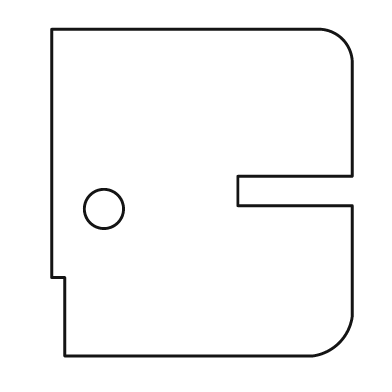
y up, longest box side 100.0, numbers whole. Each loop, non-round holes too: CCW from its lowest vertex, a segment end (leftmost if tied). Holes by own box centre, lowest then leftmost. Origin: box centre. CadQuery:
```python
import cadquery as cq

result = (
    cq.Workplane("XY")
    .moveTo(-42.0, -50.0)
    .lineTo(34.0, -50.0)
    .threePointArc((42.0, -46.0), (46.0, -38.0))
    .lineTo(46.0, -4.0)
    .lineTo(11.0, -4.0)
    .lineTo(11.0, 5.0)
    .lineTo(46.0, 5.0)
    .lineTo(46.0, 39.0)
    .threePointArc((43.0, 47.0), (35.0, 50.0))
    .lineTo(-46.0, 50.0)
    .lineTo(-46.0, -26.0)
    .lineTo(-42.0, -26.0)
    .close()
    .moveTo(-30.0, -5.0)
    .circle(6.0)
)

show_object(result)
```